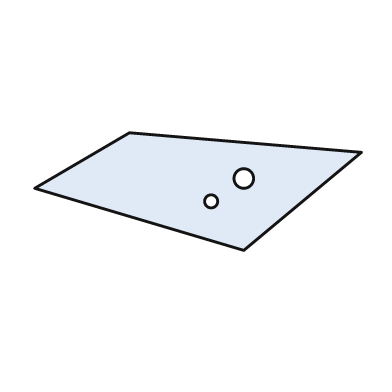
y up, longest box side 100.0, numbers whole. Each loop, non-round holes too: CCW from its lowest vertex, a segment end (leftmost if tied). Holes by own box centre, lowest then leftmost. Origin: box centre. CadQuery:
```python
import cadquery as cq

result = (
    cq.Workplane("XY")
    .moveTo(14.0, -18.0)
    .lineTo(50.0, 12.0)
    .lineTo(-21.0, 18.0)
    .lineTo(-50.0, 1.0)
    .close()
    .moveTo(4.0, -3.0)
    .circle(2.0)
    .moveTo(14.0, 4.0)
    .circle(3.0)
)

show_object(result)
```